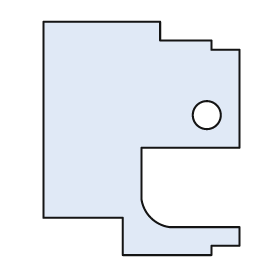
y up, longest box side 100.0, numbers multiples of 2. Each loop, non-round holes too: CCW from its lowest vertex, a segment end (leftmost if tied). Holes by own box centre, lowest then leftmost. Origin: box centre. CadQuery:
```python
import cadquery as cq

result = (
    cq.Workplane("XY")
    .moveTo(-8.0, -50.0)
    .lineTo(30.0, -50.0)
    .lineTo(30.0, -46.0)
    .lineTo(42.0, -46.0)
    .lineTo(42.0, -38.0)
    .lineTo(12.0, -38.0)
    .threePointArc((4.0, -34.0), (0.0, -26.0))
    .lineTo(0.0, -4.0)
    .lineTo(42.0, -4.0)
    .lineTo(42.0, 38.0)
    .lineTo(30.0, 38.0)
    .lineTo(30.0, 42.0)
    .lineTo(8.0, 42.0)
    .lineTo(8.0, 50.0)
    .lineTo(-42.0, 50.0)
    .lineTo(-42.0, -34.0)
    .lineTo(-8.0, -34.0)
    .close()
    .moveTo(28.0, 10.0)
    .circle(6.0)
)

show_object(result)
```